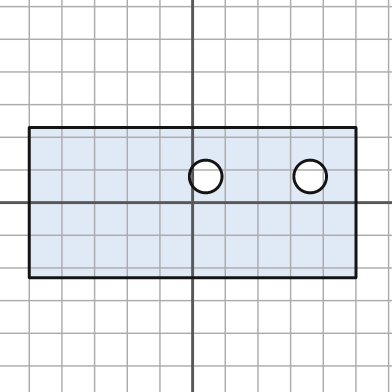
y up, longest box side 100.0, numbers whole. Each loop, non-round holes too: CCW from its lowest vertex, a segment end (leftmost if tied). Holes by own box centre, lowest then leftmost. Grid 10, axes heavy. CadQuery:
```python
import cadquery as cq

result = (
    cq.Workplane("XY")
    .moveTo(-50.0, -23.0)
    .lineTo(50.0, -23.0)
    .lineTo(50.0, 23.0)
    .lineTo(-50.0, 23.0)
    .close()
    .moveTo(4.0, 8.0)
    .circle(5.0)
    .moveTo(36.0, 8.0)
    .circle(5.0)
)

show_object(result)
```